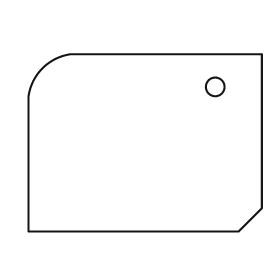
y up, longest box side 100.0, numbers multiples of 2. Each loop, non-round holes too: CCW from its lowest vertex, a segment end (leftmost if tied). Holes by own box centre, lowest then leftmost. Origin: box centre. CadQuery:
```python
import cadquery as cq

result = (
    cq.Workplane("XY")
    .moveTo(-50.0, -38.0)
    .lineTo(40.0, -38.0)
    .lineTo(50.0, -28.0)
    .lineTo(50.0, 38.0)
    .lineTo(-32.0, 38.0)
    .threePointArc((-44.0, 32.0), (-50.0, 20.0))
    .close()
    .moveTo(30.0, 24.0)
    .circle(4.0)
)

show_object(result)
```